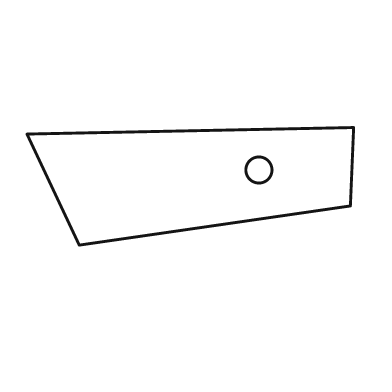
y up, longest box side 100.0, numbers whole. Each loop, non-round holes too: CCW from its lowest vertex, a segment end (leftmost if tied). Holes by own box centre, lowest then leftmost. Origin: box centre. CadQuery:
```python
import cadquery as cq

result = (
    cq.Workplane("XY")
    .moveTo(-34.0, -18.0)
    .lineTo(49.0, -6.0)
    .lineTo(50.0, 18.0)
    .lineTo(-50.0, 16.0)
    .close()
    .moveTo(21.0, 5.0)
    .circle(4.0)
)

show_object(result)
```